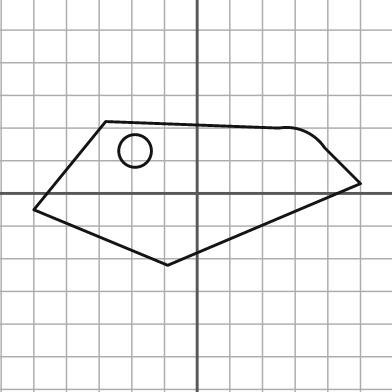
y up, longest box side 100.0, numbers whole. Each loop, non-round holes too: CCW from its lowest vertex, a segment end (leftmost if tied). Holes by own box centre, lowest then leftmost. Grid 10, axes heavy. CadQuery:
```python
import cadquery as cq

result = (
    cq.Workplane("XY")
    .moveTo(-9.0, -22.0)
    .lineTo(50.0, 3.0)
    .lineTo(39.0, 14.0)
    .threePointArc((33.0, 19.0), (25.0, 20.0))
    .lineTo(-28.0, 22.0)
    .lineTo(-50.0, -5.0)
    .close()
    .moveTo(-19.0, 13.0)
    .circle(5.0)
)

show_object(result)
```